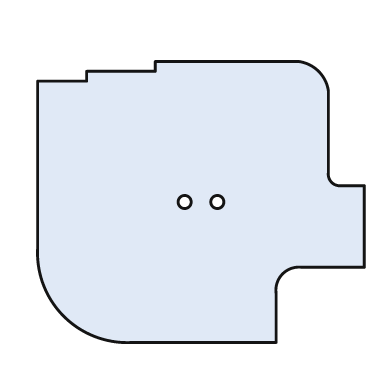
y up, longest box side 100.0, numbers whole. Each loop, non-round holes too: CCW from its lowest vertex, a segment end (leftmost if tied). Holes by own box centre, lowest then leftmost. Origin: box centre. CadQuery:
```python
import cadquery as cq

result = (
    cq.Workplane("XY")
    .moveTo(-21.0, -43.0)
    .lineTo(23.0, -43.0)
    .lineTo(23.0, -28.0)
    .threePointArc((25.0, -22.0), (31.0, -20.0))
    .lineTo(50.0, -20.0)
    .lineTo(50.0, 5.0)
    .lineTo(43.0, 5.0)
    .threePointArc((40.0, 6.0), (39.0, 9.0))
    .lineTo(39.0, 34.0)
    .threePointArc((36.0, 40.0), (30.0, 43.0))
    .lineTo(-14.0, 43.0)
    .lineTo(-14.0, 40.0)
    .lineTo(-35.0, 40.0)
    .lineTo(-35.0, 37.0)
    .lineTo(-50.0, 37.0)
    .lineTo(-50.0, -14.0)
    .threePointArc((-42.0, -35.0), (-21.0, -43.0))
    .close()
    .moveTo(-5.0, 0.0)
    .circle(2.0)
    .moveTo(5.0, 0.0)
    .circle(2.0)
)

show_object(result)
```